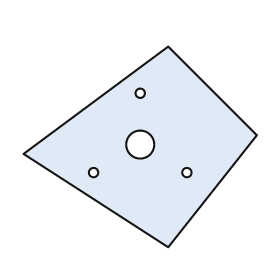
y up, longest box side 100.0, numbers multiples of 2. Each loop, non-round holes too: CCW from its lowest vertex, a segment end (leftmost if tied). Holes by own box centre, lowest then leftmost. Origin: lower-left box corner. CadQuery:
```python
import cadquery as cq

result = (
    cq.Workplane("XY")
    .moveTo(62.0, 0.0)
    .lineTo(100.0, 48.0)
    .lineTo(62.0, 86.0)
    .lineTo(0.0, 40.0)
    .close()
    .moveTo(30.0, 32.0)
    .circle(2.0)
    .moveTo(70.0, 32.0)
    .circle(2.0)
    .moveTo(50.0, 44.0)
    .circle(6.0)
    .moveTo(50.0, 66.0)
    .circle(2.0)
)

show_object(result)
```